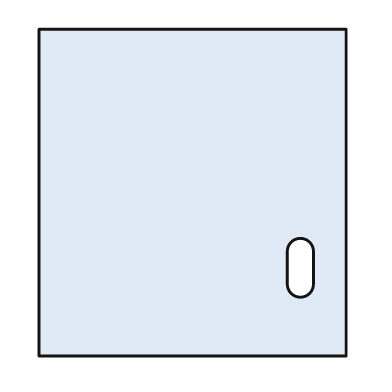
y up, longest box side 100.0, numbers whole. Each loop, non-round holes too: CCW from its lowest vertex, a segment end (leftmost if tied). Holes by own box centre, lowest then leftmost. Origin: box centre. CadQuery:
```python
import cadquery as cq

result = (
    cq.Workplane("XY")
    .moveTo(-47.0, -50.0)
    .lineTo(47.0, -50.0)
    .lineTo(47.0, 50.0)
    .lineTo(-47.0, 50.0)
    .close()
    .moveTo(29.0, -28.0)
    .threePointArc((33.0, -32.0), (37.0, -28.0))
    .lineTo(37.0, -18.0)
    .threePointArc((33.0, -14.0), (29.0, -18.0))
    .close()
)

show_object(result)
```